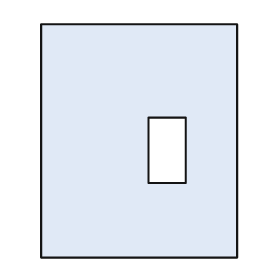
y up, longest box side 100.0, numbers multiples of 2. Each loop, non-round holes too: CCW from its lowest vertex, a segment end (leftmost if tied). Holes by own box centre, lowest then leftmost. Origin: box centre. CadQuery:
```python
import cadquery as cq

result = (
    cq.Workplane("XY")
    .moveTo(-42.0, -50.0)
    .lineTo(42.0, -50.0)
    .lineTo(42.0, 50.0)
    .lineTo(-42.0, 50.0)
    .close()
    .moveTo(4.0, -18.0)
    .lineTo(20.0, -18.0)
    .lineTo(20.0, 10.0)
    .lineTo(4.0, 10.0)
    .close()
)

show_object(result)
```